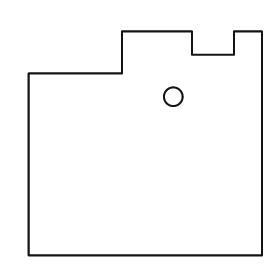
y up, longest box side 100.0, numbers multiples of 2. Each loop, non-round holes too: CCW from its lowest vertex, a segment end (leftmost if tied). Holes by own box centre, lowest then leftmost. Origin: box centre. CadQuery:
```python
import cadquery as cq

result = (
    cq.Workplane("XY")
    .moveTo(-50.0, -48.0)
    .lineTo(50.0, -48.0)
    .lineTo(50.0, 48.0)
    .lineTo(38.0, 48.0)
    .lineTo(38.0, 38.0)
    .lineTo(20.0, 38.0)
    .lineTo(20.0, 48.0)
    .lineTo(-10.0, 48.0)
    .lineTo(-10.0, 30.0)
    .lineTo(-50.0, 30.0)
    .close()
    .moveTo(12.0, 20.0)
    .circle(4.0)
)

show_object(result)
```